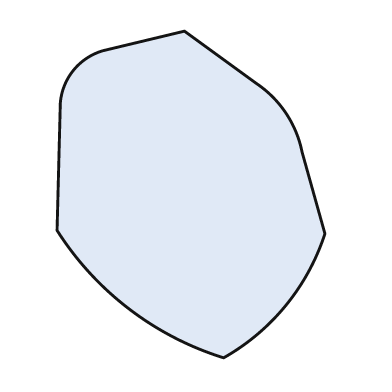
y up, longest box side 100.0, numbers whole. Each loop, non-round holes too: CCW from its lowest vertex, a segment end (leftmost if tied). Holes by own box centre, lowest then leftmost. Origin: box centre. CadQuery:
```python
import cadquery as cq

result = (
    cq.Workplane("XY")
    .moveTo(10.0, -50.0)
    .threePointArc((29.0, -34.0), (41.0, -12.0))
    .lineTo(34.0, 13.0)
    .threePointArc((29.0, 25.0), (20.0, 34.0))
    .lineTo(-2.0, 50.0)
    .lineTo(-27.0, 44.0)
    .threePointArc((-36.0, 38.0), (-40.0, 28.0))
    .lineTo(-41.0, -11.0)
    .threePointArc((-19.0, -35.0), (10.0, -50.0))
    .close()
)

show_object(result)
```